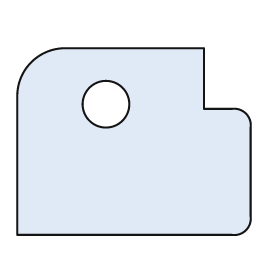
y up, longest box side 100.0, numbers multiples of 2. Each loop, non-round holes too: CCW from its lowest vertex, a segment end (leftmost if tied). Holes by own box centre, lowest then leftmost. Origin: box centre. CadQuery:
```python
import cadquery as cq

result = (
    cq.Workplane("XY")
    .moveTo(-50.0, -40.0)
    .lineTo(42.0, -40.0)
    .threePointArc((48.0, -38.0), (50.0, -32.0))
    .lineTo(50.0, 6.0)
    .threePointArc((48.0, 12.0), (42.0, 14.0))
    .lineTo(30.0, 14.0)
    .lineTo(30.0, 40.0)
    .lineTo(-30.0, 40.0)
    .threePointArc((-44.0, 34.0), (-50.0, 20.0))
    .close()
    .moveTo(-12.0, 16.0)
    .circle(10.0)
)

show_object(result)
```